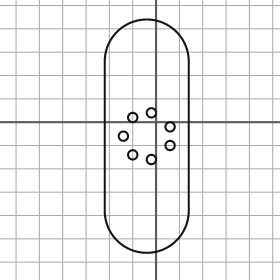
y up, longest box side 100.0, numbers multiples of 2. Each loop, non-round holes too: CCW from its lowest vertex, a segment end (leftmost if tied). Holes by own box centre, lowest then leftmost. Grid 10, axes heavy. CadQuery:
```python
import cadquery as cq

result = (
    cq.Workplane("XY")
    .moveTo(-22.0, -38.0)
    .threePointArc((-4.0, -56.0), (14.0, -38.0))
    .lineTo(14.0, 26.0)
    .threePointArc((-4.0, 44.0), (-22.0, 26.0))
    .close()
    .moveTo(-2.0, -16.0)
    .circle(2.0)
    .moveTo(-10.0, -14.0)
    .circle(2.0)
    .moveTo(6.0, -10.0)
    .circle(2.0)
    .moveTo(-14.0, -6.0)
    .circle(2.0)
    .moveTo(6.0, -2.0)
    .circle(2.0)
    .moveTo(-10.0, 2.0)
    .circle(2.0)
    .moveTo(-2.0, 4.0)
    .circle(2.0)
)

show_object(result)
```